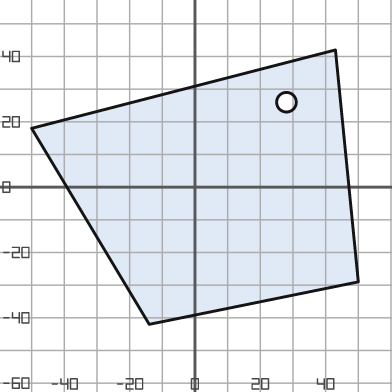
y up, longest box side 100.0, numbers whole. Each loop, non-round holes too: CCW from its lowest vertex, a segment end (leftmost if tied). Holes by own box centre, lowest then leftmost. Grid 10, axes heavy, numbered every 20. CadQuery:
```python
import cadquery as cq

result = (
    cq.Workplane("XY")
    .moveTo(-14.0, -42.0)
    .lineTo(50.0, -29.0)
    .lineTo(43.0, 42.0)
    .lineTo(-50.0, 18.0)
    .close()
    .moveTo(28.0, 26.0)
    .circle(3.0)
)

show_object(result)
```